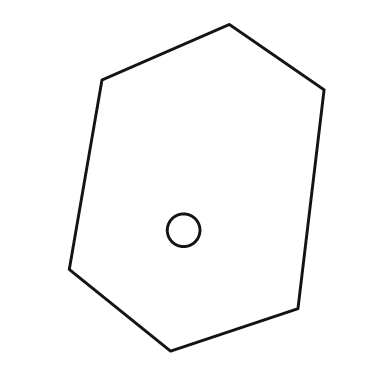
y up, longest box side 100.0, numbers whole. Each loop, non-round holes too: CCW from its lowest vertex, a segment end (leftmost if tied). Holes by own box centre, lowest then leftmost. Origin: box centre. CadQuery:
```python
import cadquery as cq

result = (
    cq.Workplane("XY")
    .moveTo(-8.0, -50.0)
    .lineTo(31.0, -37.0)
    .lineTo(39.0, 30.0)
    .lineTo(10.0, 50.0)
    .lineTo(-29.0, 33.0)
    .lineTo(-39.0, -25.0)
    .close()
    .moveTo(-4.0, -13.0)
    .circle(5.0)
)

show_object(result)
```